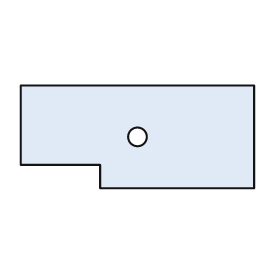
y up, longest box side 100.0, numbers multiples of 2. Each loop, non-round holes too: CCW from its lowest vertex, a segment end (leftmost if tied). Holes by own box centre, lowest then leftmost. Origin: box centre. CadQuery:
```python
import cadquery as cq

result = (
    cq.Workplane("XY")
    .moveTo(-16.0, -22.0)
    .lineTo(50.0, -22.0)
    .lineTo(50.0, 22.0)
    .lineTo(-50.0, 22.0)
    .lineTo(-50.0, -12.0)
    .lineTo(-16.0, -12.0)
    .close()
    .moveTo(0.0, 0.0)
    .circle(4.0)
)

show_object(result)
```